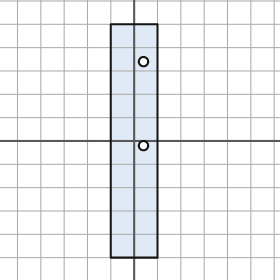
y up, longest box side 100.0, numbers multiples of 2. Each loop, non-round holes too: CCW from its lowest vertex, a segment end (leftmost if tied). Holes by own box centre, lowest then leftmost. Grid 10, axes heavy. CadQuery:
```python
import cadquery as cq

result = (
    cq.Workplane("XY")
    .moveTo(-10.0, -50.0)
    .lineTo(10.0, -50.0)
    .lineTo(10.0, 50.0)
    .lineTo(-10.0, 50.0)
    .close()
    .moveTo(4.0, -2.0)
    .circle(2.0)
    .moveTo(4.0, 34.0)
    .circle(2.0)
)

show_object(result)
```